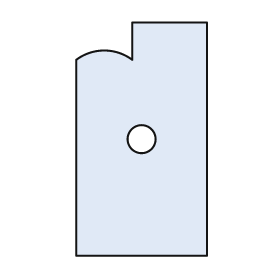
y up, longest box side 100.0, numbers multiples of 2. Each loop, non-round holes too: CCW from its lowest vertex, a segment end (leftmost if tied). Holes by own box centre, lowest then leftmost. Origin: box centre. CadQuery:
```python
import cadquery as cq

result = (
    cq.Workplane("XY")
    .moveTo(-28.0, -50.0)
    .lineTo(28.0, -50.0)
    .lineTo(28.0, 50.0)
    .lineTo(-4.0, 50.0)
    .lineTo(-4.0, 34.0)
    .threePointArc((-16.0, 38.0), (-28.0, 34.0))
    .close()
    .moveTo(0.0, 0.0)
    .circle(6.0)
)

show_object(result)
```